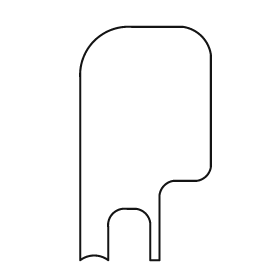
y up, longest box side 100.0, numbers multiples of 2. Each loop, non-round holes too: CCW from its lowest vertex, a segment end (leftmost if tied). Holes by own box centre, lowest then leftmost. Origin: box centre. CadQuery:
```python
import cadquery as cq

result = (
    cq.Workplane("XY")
    .moveTo(-28.0, -50.0)
    .threePointArc((-22.0, -48.0), (-16.0, -50.0))
    .lineTo(-16.0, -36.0)
    .threePointArc((-14.0, -30.0), (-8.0, -28.0))
    .lineTo(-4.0, -28.0)
    .threePointArc((0.0, -30.0), (2.0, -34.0))
    .lineTo(2.0, -50.0)
    .lineTo(6.0, -50.0)
    .lineTo(6.0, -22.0)
    .threePointArc((8.0, -18.0), (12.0, -16.0))
    .lineTo(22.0, -16.0)
    .threePointArc((26.0, -14.0), (28.0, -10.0))
    .lineTo(28.0, 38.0)
    .threePointArc((24.0, 46.0), (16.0, 50.0))
    .lineTo(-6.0, 50.0)
    .threePointArc((-22.0, 44.0), (-28.0, 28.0))
    .close()
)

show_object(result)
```